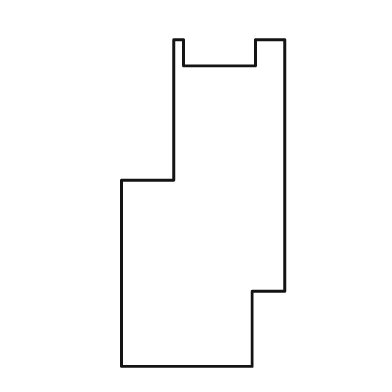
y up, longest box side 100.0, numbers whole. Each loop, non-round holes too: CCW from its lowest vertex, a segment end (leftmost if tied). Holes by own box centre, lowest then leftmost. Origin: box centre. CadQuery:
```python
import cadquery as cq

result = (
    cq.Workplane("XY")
    .moveTo(-25.0, -50.0)
    .lineTo(15.0, -50.0)
    .lineTo(15.0, -27.0)
    .lineTo(25.0, -27.0)
    .lineTo(25.0, 50.0)
    .lineTo(16.0, 50.0)
    .lineTo(16.0, 42.0)
    .lineTo(-6.0, 42.0)
    .lineTo(-6.0, 50.0)
    .lineTo(-9.0, 50.0)
    .lineTo(-9.0, 7.0)
    .lineTo(-25.0, 7.0)
    .close()
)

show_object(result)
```